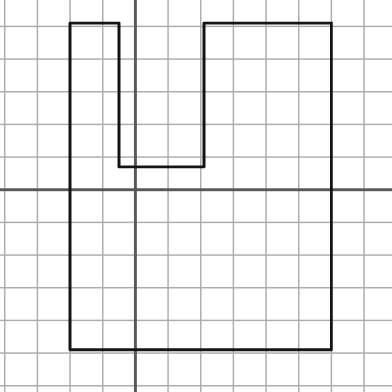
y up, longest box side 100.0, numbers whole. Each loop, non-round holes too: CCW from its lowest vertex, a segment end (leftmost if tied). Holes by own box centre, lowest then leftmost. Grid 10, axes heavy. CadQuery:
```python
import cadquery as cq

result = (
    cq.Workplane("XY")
    .moveTo(-20.0, -49.0)
    .lineTo(60.0, -49.0)
    .lineTo(60.0, 51.0)
    .lineTo(21.0, 51.0)
    .lineTo(21.0, 7.0)
    .lineTo(-5.0, 7.0)
    .lineTo(-5.0, 51.0)
    .lineTo(-20.0, 51.0)
    .close()
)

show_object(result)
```